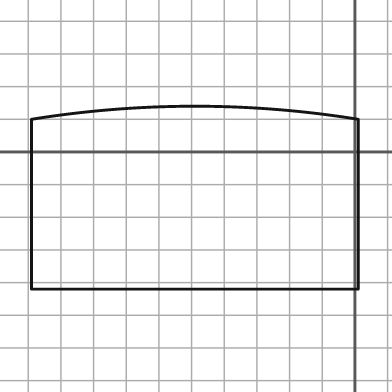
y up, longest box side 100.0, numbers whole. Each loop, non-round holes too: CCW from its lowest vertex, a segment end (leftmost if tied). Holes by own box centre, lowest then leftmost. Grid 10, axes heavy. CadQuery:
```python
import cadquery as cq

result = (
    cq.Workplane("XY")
    .moveTo(-99.0, -42.0)
    .lineTo(1.0, -42.0)
    .lineTo(1.0, 10.0)
    .threePointArc((-49.0, 14.0), (-99.0, 10.0))
    .close()
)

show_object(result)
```